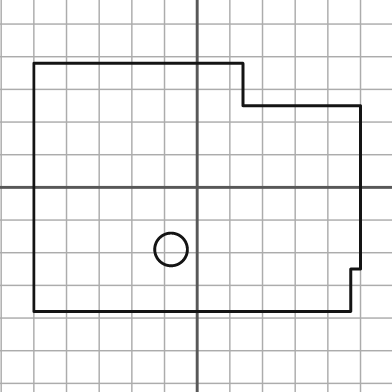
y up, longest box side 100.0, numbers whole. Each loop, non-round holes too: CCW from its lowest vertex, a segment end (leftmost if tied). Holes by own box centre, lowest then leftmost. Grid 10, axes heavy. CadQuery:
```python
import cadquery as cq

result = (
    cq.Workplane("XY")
    .moveTo(-50.0, -38.0)
    .lineTo(47.0, -38.0)
    .lineTo(47.0, -25.0)
    .lineTo(50.0, -25.0)
    .lineTo(50.0, 25.0)
    .lineTo(14.0, 25.0)
    .lineTo(14.0, 38.0)
    .lineTo(-50.0, 38.0)
    .close()
    .moveTo(-8.0, -19.0)
    .circle(5.0)
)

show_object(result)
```